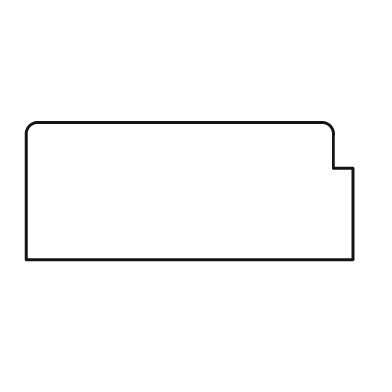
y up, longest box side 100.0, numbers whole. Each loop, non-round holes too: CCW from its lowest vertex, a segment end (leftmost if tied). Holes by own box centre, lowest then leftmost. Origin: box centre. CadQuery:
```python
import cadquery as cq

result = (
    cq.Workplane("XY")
    .moveTo(-50.0, -21.0)
    .lineTo(50.0, -21.0)
    .lineTo(50.0, 7.0)
    .lineTo(44.0, 7.0)
    .lineTo(44.0, 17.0)
    .threePointArc((43.0, 20.0), (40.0, 21.0))
    .lineTo(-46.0, 21.0)
    .threePointArc((-49.0, 20.0), (-50.0, 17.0))
    .close()
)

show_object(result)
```